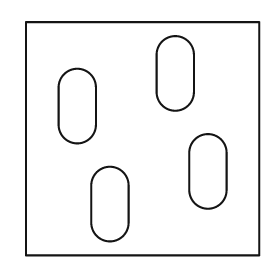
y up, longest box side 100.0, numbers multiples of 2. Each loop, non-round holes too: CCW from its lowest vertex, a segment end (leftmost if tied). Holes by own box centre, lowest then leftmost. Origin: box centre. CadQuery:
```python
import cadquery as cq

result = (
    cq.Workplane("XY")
    .moveTo(-50.0, -50.0)
    .lineTo(50.0, -50.0)
    .lineTo(50.0, 50.0)
    .lineTo(-50.0, 50.0)
    .close()
    .moveTo(-22.0, -36.0)
    .threePointArc((-14.0, -44.0), (-6.0, -36.0))
    .lineTo(-6.0, -20.0)
    .threePointArc((-14.0, -12.0), (-22.0, -20.0))
    .close()
    .moveTo(20.0, -22.0)
    .threePointArc((28.0, -30.0), (36.0, -22.0))
    .lineTo(36.0, -6.0)
    .threePointArc((28.0, 2.0), (20.0, -6.0))
    .close()
    .moveTo(-36.0, 6.0)
    .threePointArc((-28.0, -2.0), (-20.0, 6.0))
    .lineTo(-20.0, 22.0)
    .threePointArc((-28.0, 30.0), (-36.0, 22.0))
    .close()
    .moveTo(6.0, 20.0)
    .threePointArc((14.0, 12.0), (22.0, 20.0))
    .lineTo(22.0, 36.0)
    .threePointArc((14.0, 44.0), (6.0, 36.0))
    .close()
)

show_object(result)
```